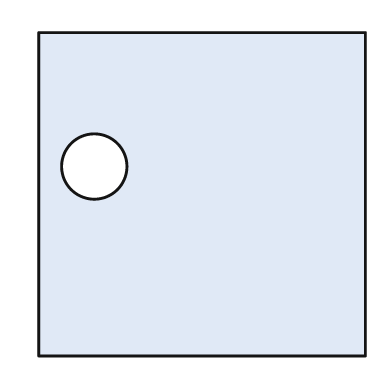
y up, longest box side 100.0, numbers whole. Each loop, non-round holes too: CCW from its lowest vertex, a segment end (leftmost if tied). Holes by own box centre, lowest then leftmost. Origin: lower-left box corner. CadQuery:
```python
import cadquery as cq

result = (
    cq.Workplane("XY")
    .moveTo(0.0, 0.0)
    .lineTo(100.0, 0.0)
    .lineTo(100.0, 99.0)
    .lineTo(0.0, 99.0)
    .close()
    .moveTo(17.0, 58.0)
    .circle(10.0)
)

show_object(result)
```